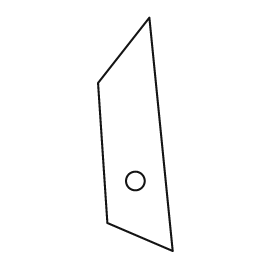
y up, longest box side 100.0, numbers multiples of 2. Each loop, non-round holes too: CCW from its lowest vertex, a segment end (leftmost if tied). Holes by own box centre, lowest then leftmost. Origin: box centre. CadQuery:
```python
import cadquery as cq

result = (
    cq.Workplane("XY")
    .moveTo(16.0, -50.0)
    .lineTo(6.0, 50.0)
    .lineTo(-16.0, 22.0)
    .lineTo(-12.0, -38.0)
    .close()
    .moveTo(0.0, -20.0)
    .circle(4.0)
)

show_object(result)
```